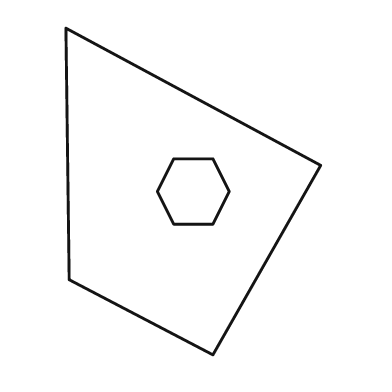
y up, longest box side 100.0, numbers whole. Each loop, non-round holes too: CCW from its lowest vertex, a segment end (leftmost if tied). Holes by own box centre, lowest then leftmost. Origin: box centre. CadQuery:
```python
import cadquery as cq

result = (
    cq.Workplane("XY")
    .moveTo(6.0, -50.0)
    .lineTo(39.0, 8.0)
    .lineTo(-39.0, 50.0)
    .lineTo(-38.0, -27.0)
    .close()
    .moveTo(-6.0, -10.0)
    .lineTo(6.0, -10.0)
    .lineTo(11.0, 0.0)
    .lineTo(6.0, 10.0)
    .lineTo(-6.0, 10.0)
    .lineTo(-11.0, 0.0)
    .close()
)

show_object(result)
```